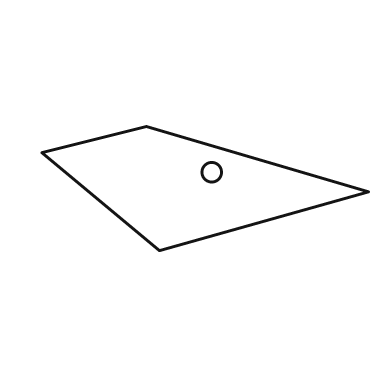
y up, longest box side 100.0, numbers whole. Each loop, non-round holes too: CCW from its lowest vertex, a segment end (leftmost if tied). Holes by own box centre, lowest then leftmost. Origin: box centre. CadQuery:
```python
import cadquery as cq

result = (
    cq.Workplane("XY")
    .moveTo(-14.0, -19.0)
    .lineTo(50.0, -1.0)
    .lineTo(-18.0, 19.0)
    .lineTo(-50.0, 11.0)
    .close()
    .moveTo(2.0, 5.0)
    .circle(3.0)
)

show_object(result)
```